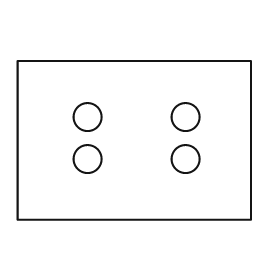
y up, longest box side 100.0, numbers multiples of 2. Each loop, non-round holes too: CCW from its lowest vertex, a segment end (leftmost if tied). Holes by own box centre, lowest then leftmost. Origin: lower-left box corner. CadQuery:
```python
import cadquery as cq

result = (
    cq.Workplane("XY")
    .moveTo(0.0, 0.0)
    .lineTo(100.0, 0.0)
    .lineTo(100.0, 68.0)
    .lineTo(0.0, 68.0)
    .close()
    .moveTo(30.0, 26.0)
    .circle(6.0)
    .moveTo(72.0, 26.0)
    .circle(6.0)
    .moveTo(30.0, 44.0)
    .circle(6.0)
    .moveTo(72.0, 44.0)
    .circle(6.0)
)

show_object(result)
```